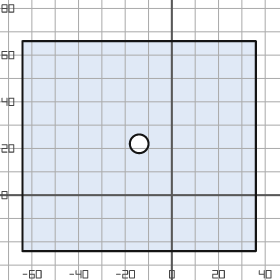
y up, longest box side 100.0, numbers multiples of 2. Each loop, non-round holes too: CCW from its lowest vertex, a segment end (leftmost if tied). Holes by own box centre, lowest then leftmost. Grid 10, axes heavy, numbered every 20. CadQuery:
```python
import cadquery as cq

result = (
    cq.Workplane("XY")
    .moveTo(-64.0, -24.0)
    .lineTo(36.0, -24.0)
    .lineTo(36.0, 66.0)
    .lineTo(-64.0, 66.0)
    .close()
    .moveTo(-14.0, 22.0)
    .circle(4.0)
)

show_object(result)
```